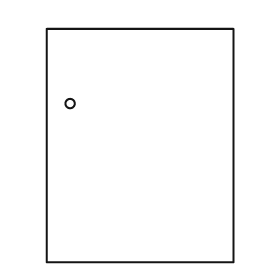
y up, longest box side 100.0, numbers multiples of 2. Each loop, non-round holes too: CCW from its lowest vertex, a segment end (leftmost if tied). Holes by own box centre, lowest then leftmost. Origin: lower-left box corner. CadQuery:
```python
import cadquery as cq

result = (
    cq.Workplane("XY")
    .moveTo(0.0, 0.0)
    .lineTo(80.0, 0.0)
    .lineTo(80.0, 100.0)
    .lineTo(0.0, 100.0)
    .close()
    .moveTo(10.0, 68.0)
    .circle(2.0)
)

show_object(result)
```